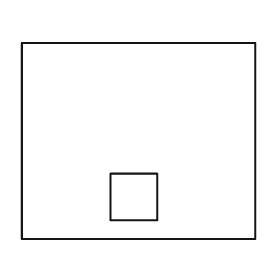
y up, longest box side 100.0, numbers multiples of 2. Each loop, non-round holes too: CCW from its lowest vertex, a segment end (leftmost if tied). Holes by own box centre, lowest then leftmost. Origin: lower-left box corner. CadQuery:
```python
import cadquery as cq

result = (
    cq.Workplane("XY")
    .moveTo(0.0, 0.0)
    .lineTo(100.0, 0.0)
    .lineTo(100.0, 84.0)
    .lineTo(0.0, 84.0)
    .close()
    .moveTo(38.0, 8.0)
    .lineTo(58.0, 8.0)
    .lineTo(58.0, 28.0)
    .lineTo(38.0, 28.0)
    .close()
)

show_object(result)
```